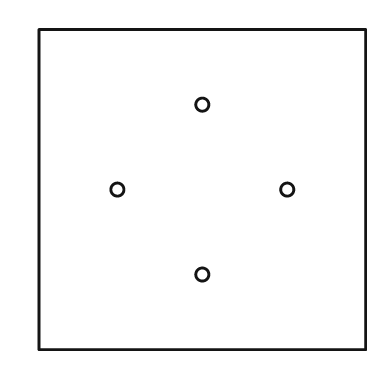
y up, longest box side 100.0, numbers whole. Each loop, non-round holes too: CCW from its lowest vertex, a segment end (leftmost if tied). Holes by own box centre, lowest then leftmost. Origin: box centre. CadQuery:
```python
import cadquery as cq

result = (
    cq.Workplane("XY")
    .moveTo(-50.0, -49.0)
    .lineTo(50.0, -49.0)
    .lineTo(50.0, 49.0)
    .lineTo(-50.0, 49.0)
    .close()
    .moveTo(0.0, -26.0)
    .circle(2.0)
    .moveTo(-26.0, 0.0)
    .circle(2.0)
    .moveTo(26.0, 0.0)
    .circle(2.0)
    .moveTo(0.0, 26.0)
    .circle(2.0)
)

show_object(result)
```